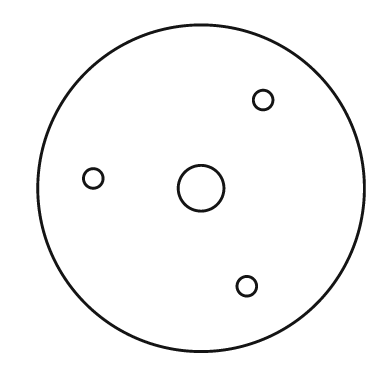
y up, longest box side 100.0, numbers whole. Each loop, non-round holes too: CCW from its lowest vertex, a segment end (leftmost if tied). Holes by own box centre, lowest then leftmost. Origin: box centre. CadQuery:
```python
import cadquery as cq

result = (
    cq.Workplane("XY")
    .moveTo(0.0, 0.0)
    .circle(50.0)
    .moveTo(14.0, -30.0)
    .circle(3.0)
    .moveTo(0.0, 0.0)
    .circle(7.0)
    .moveTo(-33.0, 3.0)
    .circle(3.0)
    .moveTo(19.0, 27.0)
    .circle(3.0)
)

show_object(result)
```